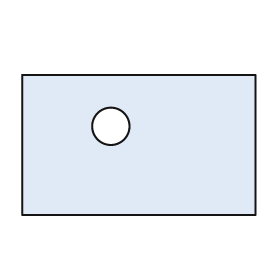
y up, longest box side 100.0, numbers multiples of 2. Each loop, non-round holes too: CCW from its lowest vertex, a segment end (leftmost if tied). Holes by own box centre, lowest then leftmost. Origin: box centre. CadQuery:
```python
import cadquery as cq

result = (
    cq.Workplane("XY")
    .moveTo(-50.0, -30.0)
    .lineTo(50.0, -30.0)
    .lineTo(50.0, 30.0)
    .lineTo(-50.0, 30.0)
    .close()
    .moveTo(-12.0, 8.0)
    .circle(8.0)
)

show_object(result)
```